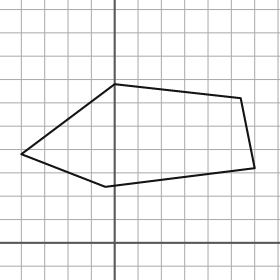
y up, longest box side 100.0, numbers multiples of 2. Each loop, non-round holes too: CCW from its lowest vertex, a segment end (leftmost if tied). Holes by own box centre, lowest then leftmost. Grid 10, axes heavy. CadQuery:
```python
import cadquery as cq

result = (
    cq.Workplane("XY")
    .moveTo(-4.0, 24.0)
    .lineTo(60.0, 32.0)
    .lineTo(54.0, 62.0)
    .lineTo(0.0, 68.0)
    .lineTo(-40.0, 38.0)
    .close()
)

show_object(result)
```